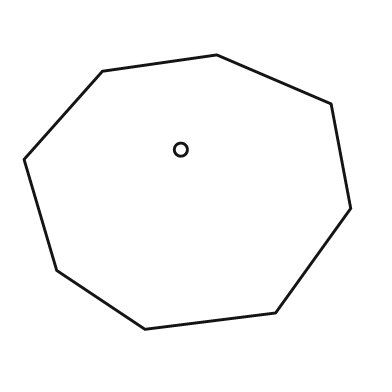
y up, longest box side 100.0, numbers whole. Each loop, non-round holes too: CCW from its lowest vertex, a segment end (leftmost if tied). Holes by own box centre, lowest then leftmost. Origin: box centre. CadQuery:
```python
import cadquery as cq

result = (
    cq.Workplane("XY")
    .moveTo(-13.0, -42.0)
    .lineTo(27.0, -37.0)
    .lineTo(50.0, -5.0)
    .lineTo(44.0, 27.0)
    .lineTo(9.0, 42.0)
    .lineTo(-26.0, 37.0)
    .lineTo(-50.0, 10.0)
    .lineTo(-40.0, -24.0)
    .close()
    .moveTo(-2.0, 13.0)
    .circle(2.0)
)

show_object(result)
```